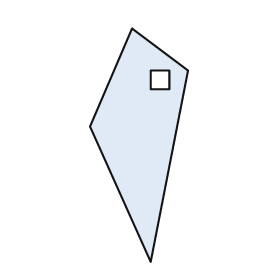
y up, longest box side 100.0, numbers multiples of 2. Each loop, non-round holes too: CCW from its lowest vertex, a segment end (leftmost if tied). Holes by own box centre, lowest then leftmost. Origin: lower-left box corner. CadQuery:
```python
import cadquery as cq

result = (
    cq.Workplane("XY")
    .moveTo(26.0, 0.0)
    .lineTo(42.0, 82.0)
    .lineTo(18.0, 100.0)
    .lineTo(0.0, 58.0)
    .close()
    .moveTo(26.0, 74.0)
    .lineTo(34.0, 74.0)
    .lineTo(34.0, 82.0)
    .lineTo(26.0, 82.0)
    .close()
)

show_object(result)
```